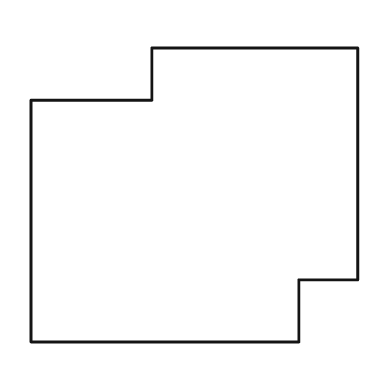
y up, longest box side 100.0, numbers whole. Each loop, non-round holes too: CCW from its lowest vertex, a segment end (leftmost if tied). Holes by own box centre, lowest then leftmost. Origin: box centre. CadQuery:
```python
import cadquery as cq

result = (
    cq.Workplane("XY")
    .moveTo(-50.0, -45.0)
    .lineTo(32.0, -45.0)
    .lineTo(32.0, -26.0)
    .lineTo(50.0, -26.0)
    .lineTo(50.0, 45.0)
    .lineTo(-13.0, 45.0)
    .lineTo(-13.0, 29.0)
    .lineTo(-50.0, 29.0)
    .close()
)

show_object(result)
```